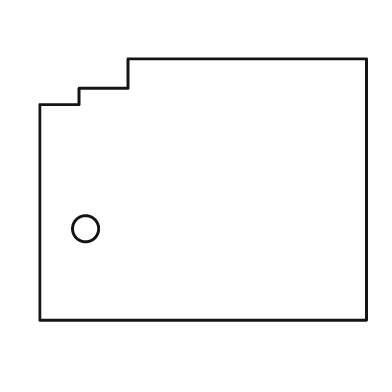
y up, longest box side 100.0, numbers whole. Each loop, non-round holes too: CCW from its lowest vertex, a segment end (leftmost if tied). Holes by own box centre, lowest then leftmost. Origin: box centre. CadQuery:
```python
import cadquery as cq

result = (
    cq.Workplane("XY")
    .moveTo(-50.0, -40.0)
    .lineTo(50.0, -40.0)
    .lineTo(50.0, 40.0)
    .lineTo(-23.0, 40.0)
    .lineTo(-23.0, 31.0)
    .lineTo(-38.0, 31.0)
    .lineTo(-38.0, 26.0)
    .lineTo(-50.0, 26.0)
    .close()
    .moveTo(-36.0, -12.0)
    .circle(4.0)
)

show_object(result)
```